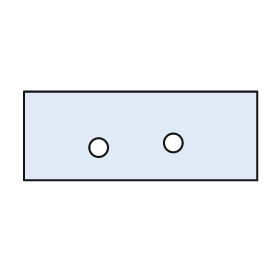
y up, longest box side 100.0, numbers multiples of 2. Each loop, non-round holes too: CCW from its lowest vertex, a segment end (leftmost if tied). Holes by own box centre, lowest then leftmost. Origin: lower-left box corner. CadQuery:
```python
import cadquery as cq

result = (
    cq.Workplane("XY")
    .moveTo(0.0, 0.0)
    .lineTo(100.0, 0.0)
    .lineTo(100.0, 38.0)
    .lineTo(0.0, 38.0)
    .close()
    .moveTo(32.0, 14.0)
    .circle(4.0)
    .moveTo(64.0, 16.0)
    .circle(4.0)
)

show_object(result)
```